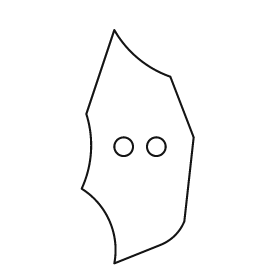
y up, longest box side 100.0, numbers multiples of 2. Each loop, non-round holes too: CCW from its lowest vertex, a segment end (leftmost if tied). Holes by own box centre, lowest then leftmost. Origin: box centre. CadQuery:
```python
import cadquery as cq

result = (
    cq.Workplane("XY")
    .moveTo(-10.0, -50.0)
    .lineTo(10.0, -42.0)
    .threePointArc((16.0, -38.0), (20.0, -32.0))
    .lineTo(24.0, 4.0)
    .lineTo(14.0, 30.0)
    .threePointArc((0.0, 38.0), (-10.0, 50.0))
    .lineTo(-22.0, 14.0)
    .threePointArc((-20.0, -2.0), (-24.0, -18.0))
    .threePointArc((-12.0, -32.0), (-10.0, -50.0))
    .close()
    .moveTo(-6.0, 0.0)
    .circle(4.0)
    .moveTo(8.0, 0.0)
    .circle(4.0)
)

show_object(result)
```